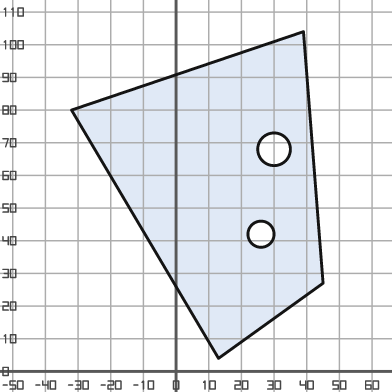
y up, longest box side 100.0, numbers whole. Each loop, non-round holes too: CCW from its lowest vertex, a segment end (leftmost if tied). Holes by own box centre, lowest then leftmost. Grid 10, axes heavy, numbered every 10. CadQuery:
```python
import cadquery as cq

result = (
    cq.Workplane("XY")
    .moveTo(13.0, 4.0)
    .lineTo(45.0, 27.0)
    .lineTo(39.0, 104.0)
    .lineTo(-32.0, 80.0)
    .close()
    .moveTo(26.0, 42.0)
    .circle(4.0)
    .moveTo(30.0, 68.0)
    .circle(5.0)
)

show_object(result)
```